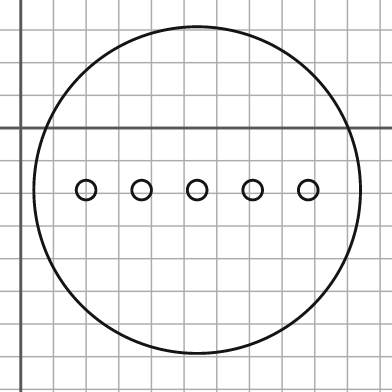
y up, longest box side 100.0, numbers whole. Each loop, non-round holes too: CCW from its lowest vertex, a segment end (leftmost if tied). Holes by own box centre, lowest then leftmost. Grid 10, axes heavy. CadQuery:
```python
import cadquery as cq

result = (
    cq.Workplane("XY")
    .moveTo(54.0, -19.0)
    .circle(50.0)
    .moveTo(20.0, -19.0)
    .circle(3.0)
    .moveTo(37.0, -19.0)
    .circle(3.0)
    .moveTo(54.0, -19.0)
    .circle(3.0)
    .moveTo(71.0, -19.0)
    .circle(3.0)
    .moveTo(88.0, -19.0)
    .circle(3.0)
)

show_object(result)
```